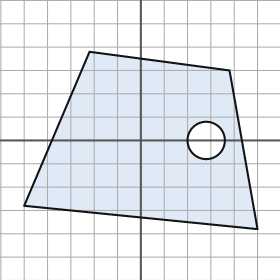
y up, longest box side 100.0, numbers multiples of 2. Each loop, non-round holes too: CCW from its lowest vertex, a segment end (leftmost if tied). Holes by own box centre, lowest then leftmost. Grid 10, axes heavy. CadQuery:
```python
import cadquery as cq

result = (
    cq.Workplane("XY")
    .moveTo(50.0, -38.0)
    .lineTo(38.0, 30.0)
    .lineTo(-22.0, 38.0)
    .lineTo(-50.0, -28.0)
    .close()
    .moveTo(28.0, 0.0)
    .circle(8.0)
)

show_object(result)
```